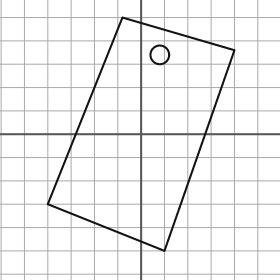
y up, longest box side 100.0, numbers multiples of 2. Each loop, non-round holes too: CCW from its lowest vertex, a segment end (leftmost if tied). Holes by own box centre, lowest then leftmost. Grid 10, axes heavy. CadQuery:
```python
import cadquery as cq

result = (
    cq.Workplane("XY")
    .moveTo(10.0, -50.0)
    .lineTo(40.0, 36.0)
    .lineTo(-8.0, 50.0)
    .lineTo(-40.0, -30.0)
    .close()
    .moveTo(8.0, 34.0)
    .circle(4.0)
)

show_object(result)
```